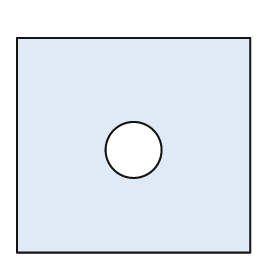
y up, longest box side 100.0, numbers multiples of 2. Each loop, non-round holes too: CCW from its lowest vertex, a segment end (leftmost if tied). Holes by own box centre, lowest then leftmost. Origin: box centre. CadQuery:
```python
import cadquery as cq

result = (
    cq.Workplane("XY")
    .moveTo(-50.0, -46.0)
    .lineTo(50.0, -46.0)
    .lineTo(50.0, 46.0)
    .lineTo(-50.0, 46.0)
    .close()
    .moveTo(0.0, -2.0)
    .circle(12.0)
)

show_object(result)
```